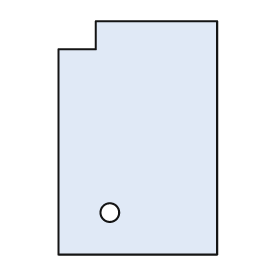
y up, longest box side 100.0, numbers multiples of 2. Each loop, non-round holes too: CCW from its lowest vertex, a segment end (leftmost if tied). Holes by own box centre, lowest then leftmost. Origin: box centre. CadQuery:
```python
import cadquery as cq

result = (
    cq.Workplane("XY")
    .moveTo(-34.0, -50.0)
    .lineTo(34.0, -50.0)
    .lineTo(34.0, 50.0)
    .lineTo(-18.0, 50.0)
    .lineTo(-18.0, 38.0)
    .lineTo(-34.0, 38.0)
    .close()
    .moveTo(-12.0, -32.0)
    .circle(4.0)
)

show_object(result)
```